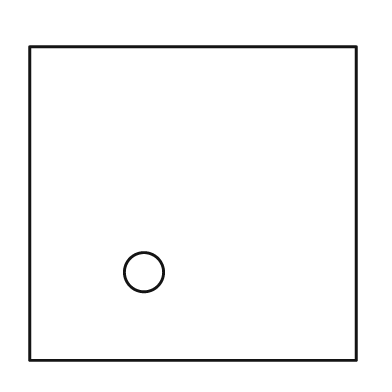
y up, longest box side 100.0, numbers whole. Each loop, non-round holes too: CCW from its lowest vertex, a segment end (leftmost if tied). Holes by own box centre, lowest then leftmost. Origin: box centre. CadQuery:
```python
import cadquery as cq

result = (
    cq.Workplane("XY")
    .moveTo(-50.0, -48.0)
    .lineTo(50.0, -48.0)
    .lineTo(50.0, 48.0)
    .lineTo(-50.0, 48.0)
    .close()
    .moveTo(-15.0, -21.0)
    .circle(6.0)
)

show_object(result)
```